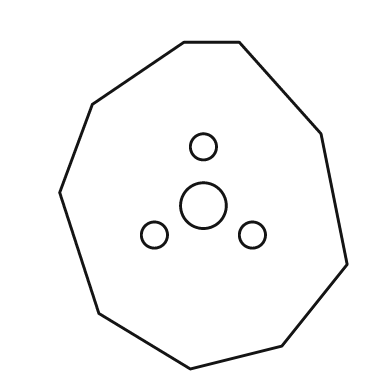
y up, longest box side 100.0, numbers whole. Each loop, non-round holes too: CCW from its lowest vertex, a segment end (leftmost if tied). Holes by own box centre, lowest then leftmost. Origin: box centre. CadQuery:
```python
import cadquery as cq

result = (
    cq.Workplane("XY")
    .moveTo(-4.0, -50.0)
    .lineTo(24.0, -43.0)
    .lineTo(44.0, -18.0)
    .lineTo(36.0, 22.0)
    .lineTo(11.0, 50.0)
    .lineTo(-6.0, 50.0)
    .lineTo(-34.0, 31.0)
    .lineTo(-44.0, 4.0)
    .lineTo(-32.0, -33.0)
    .close()
    .moveTo(-15.0, -9.0)
    .circle(4.0)
    .moveTo(15.0, -9.0)
    .circle(4.0)
    .moveTo(0.0, 0.0)
    .circle(7.0)
    .moveTo(0.0, 18.0)
    .circle(4.0)
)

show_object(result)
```